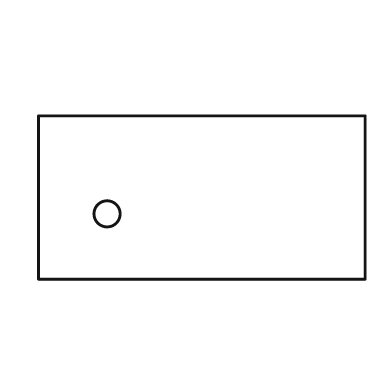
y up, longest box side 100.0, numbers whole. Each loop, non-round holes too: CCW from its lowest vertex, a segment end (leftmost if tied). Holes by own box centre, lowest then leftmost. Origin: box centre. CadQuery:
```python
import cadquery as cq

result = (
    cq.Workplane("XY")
    .moveTo(-50.0, -25.0)
    .lineTo(50.0, -25.0)
    .lineTo(50.0, 25.0)
    .lineTo(-50.0, 25.0)
    .close()
    .moveTo(-29.0, -5.0)
    .circle(4.0)
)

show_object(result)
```